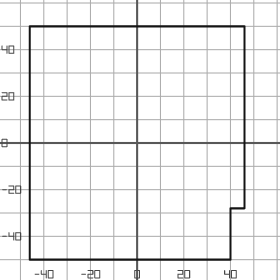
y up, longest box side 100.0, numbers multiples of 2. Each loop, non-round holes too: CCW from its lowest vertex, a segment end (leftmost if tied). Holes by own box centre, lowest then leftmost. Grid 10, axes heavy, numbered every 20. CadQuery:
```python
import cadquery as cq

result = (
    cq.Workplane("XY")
    .moveTo(-46.0, -50.0)
    .lineTo(40.0, -50.0)
    .lineTo(40.0, -28.0)
    .lineTo(46.0, -28.0)
    .lineTo(46.0, 50.0)
    .lineTo(-46.0, 50.0)
    .close()
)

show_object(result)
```